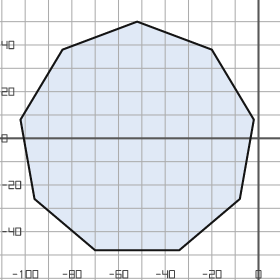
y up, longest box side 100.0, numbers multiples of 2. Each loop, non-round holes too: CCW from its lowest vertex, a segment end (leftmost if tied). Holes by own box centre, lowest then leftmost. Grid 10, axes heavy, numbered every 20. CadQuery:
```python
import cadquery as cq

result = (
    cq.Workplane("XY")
    .moveTo(-70.0, -48.0)
    .lineTo(-34.0, -48.0)
    .lineTo(-8.0, -26.0)
    .lineTo(-2.0, 8.0)
    .lineTo(-20.0, 38.0)
    .lineTo(-52.0, 50.0)
    .lineTo(-84.0, 38.0)
    .lineTo(-102.0, 8.0)
    .lineTo(-96.0, -26.0)
    .close()
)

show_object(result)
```